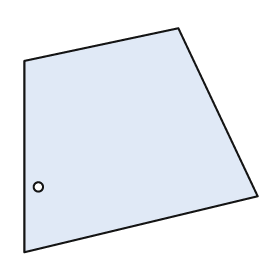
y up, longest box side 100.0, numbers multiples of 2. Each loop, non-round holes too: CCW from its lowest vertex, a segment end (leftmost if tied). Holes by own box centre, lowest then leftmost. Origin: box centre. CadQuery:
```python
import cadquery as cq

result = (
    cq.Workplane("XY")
    .moveTo(-50.0, -48.0)
    .lineTo(50.0, -24.0)
    .lineTo(16.0, 48.0)
    .lineTo(-50.0, 34.0)
    .close()
    .moveTo(-44.0, -20.0)
    .circle(2.0)
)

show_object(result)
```